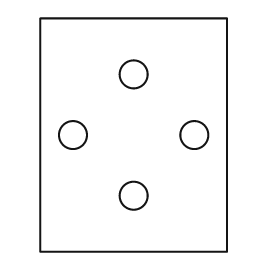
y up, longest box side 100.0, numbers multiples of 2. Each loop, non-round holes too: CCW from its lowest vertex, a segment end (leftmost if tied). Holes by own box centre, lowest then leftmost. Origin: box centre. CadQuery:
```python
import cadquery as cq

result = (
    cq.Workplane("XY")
    .moveTo(-40.0, -50.0)
    .lineTo(40.0, -50.0)
    .lineTo(40.0, 50.0)
    .lineTo(-40.0, 50.0)
    .close()
    .moveTo(0.0, -26.0)
    .circle(6.0)
    .moveTo(-26.0, 0.0)
    .circle(6.0)
    .moveTo(26.0, 0.0)
    .circle(6.0)
    .moveTo(0.0, 26.0)
    .circle(6.0)
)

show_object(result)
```